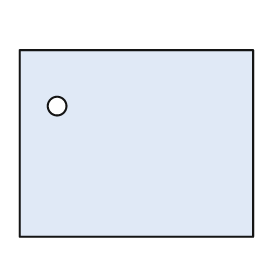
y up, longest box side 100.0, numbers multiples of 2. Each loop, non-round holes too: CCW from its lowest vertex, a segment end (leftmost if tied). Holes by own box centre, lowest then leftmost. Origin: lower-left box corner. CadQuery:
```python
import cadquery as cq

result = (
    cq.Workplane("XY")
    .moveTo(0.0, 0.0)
    .lineTo(100.0, 0.0)
    .lineTo(100.0, 80.0)
    .lineTo(0.0, 80.0)
    .close()
    .moveTo(16.0, 56.0)
    .circle(4.0)
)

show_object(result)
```